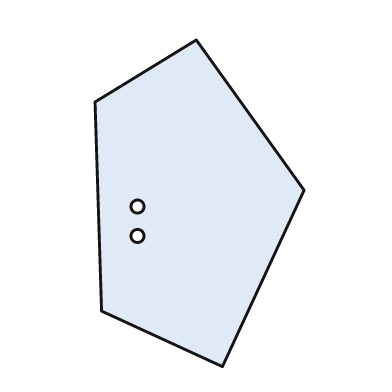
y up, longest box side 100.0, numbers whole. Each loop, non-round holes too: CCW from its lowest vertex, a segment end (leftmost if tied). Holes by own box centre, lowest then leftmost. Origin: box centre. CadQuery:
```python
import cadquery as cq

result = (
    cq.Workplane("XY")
    .moveTo(7.0, -50.0)
    .lineTo(32.0, 4.0)
    .lineTo(-1.0, 50.0)
    .lineTo(-32.0, 31.0)
    .lineTo(-30.0, -33.0)
    .close()
    .moveTo(-19.0, -10.0)
    .circle(2.0)
    .moveTo(-19.0, -1.0)
    .circle(2.0)
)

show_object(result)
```